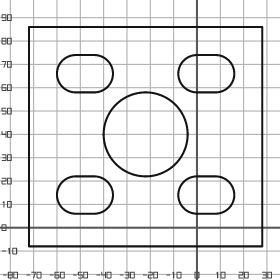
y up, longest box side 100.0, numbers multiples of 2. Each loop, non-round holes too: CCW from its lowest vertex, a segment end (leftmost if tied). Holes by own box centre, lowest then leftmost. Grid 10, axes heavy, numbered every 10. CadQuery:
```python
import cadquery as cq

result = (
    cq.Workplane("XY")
    .moveTo(-72.0, -8.0)
    .lineTo(28.0, -8.0)
    .lineTo(28.0, 86.0)
    .lineTo(-72.0, 86.0)
    .close()
    .moveTo(-52.0, 6.0)
    .lineTo(-44.0, 6.0)
    .threePointArc((-36.0, 14.0), (-44.0, 22.0))
    .lineTo(-52.0, 22.0)
    .threePointArc((-60.0, 14.0), (-52.0, 6.0))
    .close()
    .moveTo(0.0, 6.0)
    .lineTo(8.0, 6.0)
    .threePointArc((16.0, 14.0), (8.0, 22.0))
    .lineTo(0.0, 22.0)
    .threePointArc((-8.0, 14.0), (0.0, 6.0))
    .close()
    .moveTo(-22.0, 40.0)
    .circle(18.0)
    .moveTo(-52.0, 58.0)
    .lineTo(-44.0, 58.0)
    .threePointArc((-36.0, 66.0), (-44.0, 74.0))
    .lineTo(-52.0, 74.0)
    .threePointArc((-60.0, 66.0), (-52.0, 58.0))
    .close()
    .moveTo(0.0, 58.0)
    .lineTo(8.0, 58.0)
    .threePointArc((16.0, 66.0), (8.0, 74.0))
    .lineTo(0.0, 74.0)
    .threePointArc((-8.0, 66.0), (0.0, 58.0))
    .close()
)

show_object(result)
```